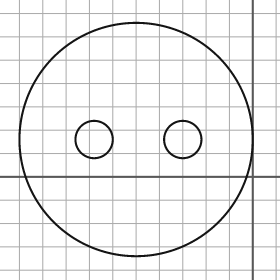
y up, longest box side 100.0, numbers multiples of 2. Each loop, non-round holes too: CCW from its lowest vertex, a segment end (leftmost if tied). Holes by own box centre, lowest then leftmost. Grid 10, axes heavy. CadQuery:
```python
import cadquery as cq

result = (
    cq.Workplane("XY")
    .moveTo(-50.0, 16.0)
    .circle(50.0)
    .moveTo(-68.0, 16.0)
    .circle(8.0)
    .moveTo(-30.0, 16.0)
    .circle(8.0)
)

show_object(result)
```